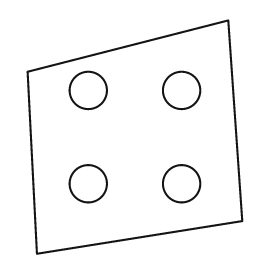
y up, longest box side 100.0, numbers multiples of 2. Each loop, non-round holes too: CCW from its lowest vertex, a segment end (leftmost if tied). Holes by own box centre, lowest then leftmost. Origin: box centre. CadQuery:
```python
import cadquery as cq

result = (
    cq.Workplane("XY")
    .moveTo(-42.0, -50.0)
    .lineTo(46.0, -36.0)
    .lineTo(40.0, 50.0)
    .lineTo(-46.0, 28.0)
    .close()
    .moveTo(-20.0, -20.0)
    .circle(8.0)
    .moveTo(20.0, -20.0)
    .circle(8.0)
    .moveTo(-20.0, 20.0)
    .circle(8.0)
    .moveTo(20.0, 20.0)
    .circle(8.0)
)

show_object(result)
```